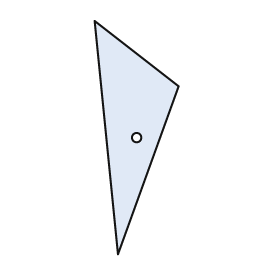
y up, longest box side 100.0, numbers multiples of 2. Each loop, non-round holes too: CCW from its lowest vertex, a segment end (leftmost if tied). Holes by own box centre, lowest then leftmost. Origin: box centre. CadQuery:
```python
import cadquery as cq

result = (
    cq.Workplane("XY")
    .moveTo(-8.0, -50.0)
    .lineTo(18.0, 22.0)
    .lineTo(-18.0, 50.0)
    .close()
    .moveTo(0.0, 0.0)
    .circle(2.0)
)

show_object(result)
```